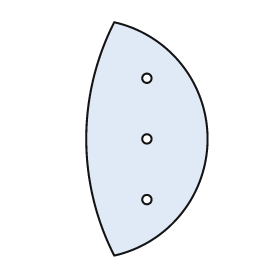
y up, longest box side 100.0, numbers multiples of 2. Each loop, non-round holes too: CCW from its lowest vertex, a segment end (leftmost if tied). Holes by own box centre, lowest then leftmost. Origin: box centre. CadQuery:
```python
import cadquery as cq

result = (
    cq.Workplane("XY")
    .moveTo(-14.0, -50.0)
    .threePointArc((26.0, 0.0), (-14.0, 50.0))
    .threePointArc((-26.0, 0.0), (-14.0, -50.0))
    .close()
    .moveTo(0.0, -26.0)
    .circle(2.0)
    .moveTo(0.0, 0.0)
    .circle(2.0)
    .moveTo(0.0, 26.0)
    .circle(2.0)
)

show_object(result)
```